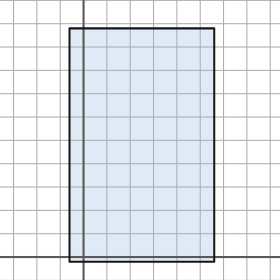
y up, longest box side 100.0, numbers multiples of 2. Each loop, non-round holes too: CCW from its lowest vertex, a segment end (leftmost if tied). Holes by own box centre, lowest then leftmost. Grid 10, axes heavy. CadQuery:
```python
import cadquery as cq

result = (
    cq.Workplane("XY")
    .moveTo(-6.0, -2.0)
    .lineTo(56.0, -2.0)
    .lineTo(56.0, 98.0)
    .lineTo(-6.0, 98.0)
    .close()
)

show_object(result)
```